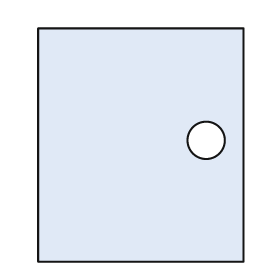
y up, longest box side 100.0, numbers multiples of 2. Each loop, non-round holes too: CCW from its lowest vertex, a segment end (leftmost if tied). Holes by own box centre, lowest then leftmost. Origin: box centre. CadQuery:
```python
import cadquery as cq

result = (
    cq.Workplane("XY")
    .moveTo(-44.0, -50.0)
    .lineTo(44.0, -50.0)
    .lineTo(44.0, 50.0)
    .lineTo(-44.0, 50.0)
    .close()
    .moveTo(28.0, 2.0)
    .circle(8.0)
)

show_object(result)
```